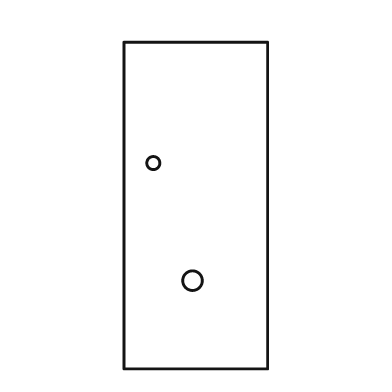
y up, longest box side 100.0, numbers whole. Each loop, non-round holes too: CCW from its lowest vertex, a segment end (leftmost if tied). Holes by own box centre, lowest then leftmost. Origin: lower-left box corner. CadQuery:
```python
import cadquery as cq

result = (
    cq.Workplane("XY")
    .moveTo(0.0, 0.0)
    .lineTo(44.0, 0.0)
    .lineTo(44.0, 100.0)
    .lineTo(0.0, 100.0)
    .close()
    .moveTo(21.0, 27.0)
    .circle(3.0)
    .moveTo(9.0, 63.0)
    .circle(2.0)
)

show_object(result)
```